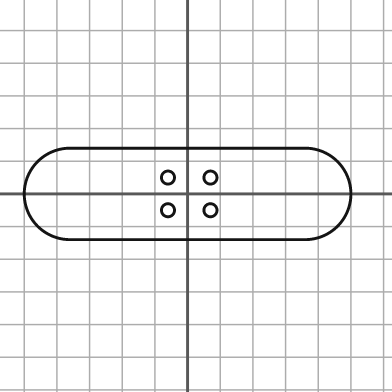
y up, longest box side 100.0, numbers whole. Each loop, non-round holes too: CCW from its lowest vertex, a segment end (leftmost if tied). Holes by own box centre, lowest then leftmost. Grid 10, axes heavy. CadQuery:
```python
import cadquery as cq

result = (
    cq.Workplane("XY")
    .moveTo(-36.0, -14.0)
    .lineTo(36.0, -14.0)
    .threePointArc((50.0, 0.0), (36.0, 14.0))
    .lineTo(-36.0, 14.0)
    .threePointArc((-50.0, 0.0), (-36.0, -14.0))
    .close()
    .moveTo(-6.0, -5.0)
    .circle(2.0)
    .moveTo(7.0, -5.0)
    .circle(2.0)
    .moveTo(-6.0, 5.0)
    .circle(2.0)
    .moveTo(7.0, 5.0)
    .circle(2.0)
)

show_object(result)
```